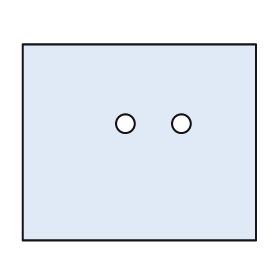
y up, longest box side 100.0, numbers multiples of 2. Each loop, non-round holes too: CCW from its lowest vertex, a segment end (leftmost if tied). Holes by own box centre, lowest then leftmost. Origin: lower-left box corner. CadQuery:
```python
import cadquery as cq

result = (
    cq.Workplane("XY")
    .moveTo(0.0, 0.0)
    .lineTo(100.0, 0.0)
    .lineTo(100.0, 84.0)
    .lineTo(0.0, 84.0)
    .close()
    .moveTo(44.0, 50.0)
    .circle(4.0)
    .moveTo(68.0, 50.0)
    .circle(4.0)
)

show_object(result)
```